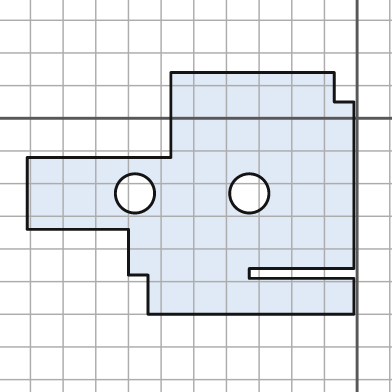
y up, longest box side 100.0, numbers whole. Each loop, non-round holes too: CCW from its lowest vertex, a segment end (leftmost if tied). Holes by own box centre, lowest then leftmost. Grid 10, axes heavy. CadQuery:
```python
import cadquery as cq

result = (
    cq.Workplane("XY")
    .moveTo(-64.0, -60.0)
    .lineTo(-1.0, -60.0)
    .lineTo(-1.0, -49.0)
    .lineTo(-33.0, -49.0)
    .lineTo(-33.0, -46.0)
    .lineTo(-1.0, -46.0)
    .lineTo(-1.0, 5.0)
    .lineTo(-7.0, 5.0)
    .lineTo(-7.0, 14.0)
    .lineTo(-57.0, 14.0)
    .lineTo(-57.0, -12.0)
    .lineTo(-101.0, -12.0)
    .lineTo(-101.0, -34.0)
    .lineTo(-70.0, -34.0)
    .lineTo(-70.0, -48.0)
    .lineTo(-64.0, -48.0)
    .close()
    .moveTo(-68.0, -23.0)
    .circle(6.0)
    .moveTo(-33.0, -23.0)
    .circle(6.0)
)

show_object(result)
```